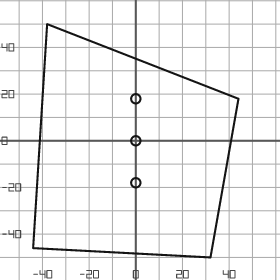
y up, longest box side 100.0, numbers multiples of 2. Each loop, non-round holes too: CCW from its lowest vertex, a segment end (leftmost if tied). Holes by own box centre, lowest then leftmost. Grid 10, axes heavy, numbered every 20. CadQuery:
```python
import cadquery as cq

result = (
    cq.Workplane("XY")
    .moveTo(32.0, -50.0)
    .lineTo(44.0, 18.0)
    .lineTo(-38.0, 50.0)
    .lineTo(-44.0, -46.0)
    .close()
    .moveTo(0.0, -18.0)
    .circle(2.0)
    .moveTo(0.0, 0.0)
    .circle(2.0)
    .moveTo(0.0, 18.0)
    .circle(2.0)
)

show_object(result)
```